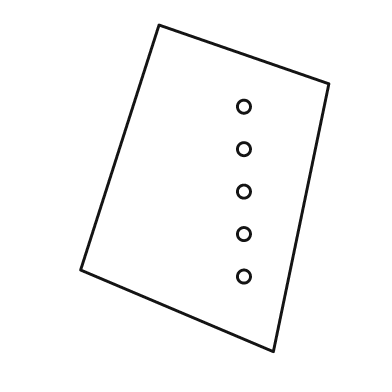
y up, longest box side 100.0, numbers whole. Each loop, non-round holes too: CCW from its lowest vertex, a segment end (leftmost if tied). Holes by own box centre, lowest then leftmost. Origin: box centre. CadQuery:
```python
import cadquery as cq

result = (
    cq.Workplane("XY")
    .moveTo(21.0, -50.0)
    .lineTo(38.0, 32.0)
    .lineTo(-14.0, 50.0)
    .lineTo(-38.0, -25.0)
    .close()
    .moveTo(12.0, -27.0)
    .circle(2.0)
    .moveTo(12.0, -14.0)
    .circle(2.0)
    .moveTo(12.0, -1.0)
    .circle(2.0)
    .moveTo(12.0, 12.0)
    .circle(2.0)
    .moveTo(12.0, 25.0)
    .circle(2.0)
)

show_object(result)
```